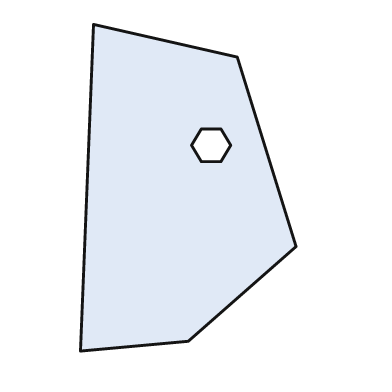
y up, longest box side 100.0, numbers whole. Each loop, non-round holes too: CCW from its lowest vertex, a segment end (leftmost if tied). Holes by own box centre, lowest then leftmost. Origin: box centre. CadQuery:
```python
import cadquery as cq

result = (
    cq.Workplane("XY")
    .moveTo(-33.0, -50.0)
    .lineTo(0.0, -47.0)
    .lineTo(33.0, -18.0)
    .lineTo(15.0, 40.0)
    .lineTo(-29.0, 50.0)
    .close()
    .moveTo(4.0, 8.0)
    .lineTo(10.0, 8.0)
    .lineTo(13.0, 13.0)
    .lineTo(10.0, 18.0)
    .lineTo(4.0, 18.0)
    .lineTo(1.0, 13.0)
    .close()
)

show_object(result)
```